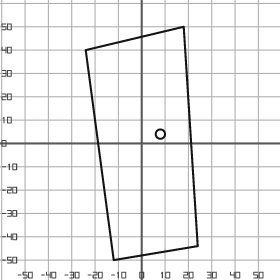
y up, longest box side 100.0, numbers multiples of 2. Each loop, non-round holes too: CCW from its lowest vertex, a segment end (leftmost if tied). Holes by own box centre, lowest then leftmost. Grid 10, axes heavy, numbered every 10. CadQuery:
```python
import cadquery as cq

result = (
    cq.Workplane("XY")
    .moveTo(-12.0, -50.0)
    .lineTo(24.0, -44.0)
    .lineTo(18.0, 50.0)
    .lineTo(-24.0, 40.0)
    .close()
    .moveTo(8.0, 4.0)
    .circle(2.0)
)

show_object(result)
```